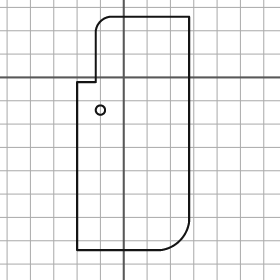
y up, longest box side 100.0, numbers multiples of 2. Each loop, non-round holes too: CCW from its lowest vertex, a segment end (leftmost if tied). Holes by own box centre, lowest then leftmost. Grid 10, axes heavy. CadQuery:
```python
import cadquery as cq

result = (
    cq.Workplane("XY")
    .moveTo(-20.0, -74.0)
    .lineTo(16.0, -74.0)
    .threePointArc((24.0, -70.0), (28.0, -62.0))
    .lineTo(28.0, 26.0)
    .lineTo(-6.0, 26.0)
    .threePointArc((-10.0, 24.0), (-12.0, 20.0))
    .lineTo(-12.0, -2.0)
    .lineTo(-20.0, -2.0)
    .close()
    .moveTo(-10.0, -14.0)
    .circle(2.0)
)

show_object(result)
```